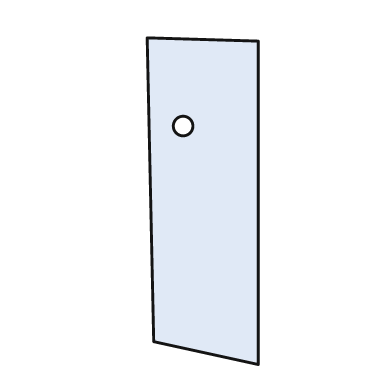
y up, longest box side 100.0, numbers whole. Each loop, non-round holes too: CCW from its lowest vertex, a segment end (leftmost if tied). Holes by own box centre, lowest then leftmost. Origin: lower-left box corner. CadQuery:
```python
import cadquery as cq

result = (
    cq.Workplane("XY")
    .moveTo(34.0, 0.0)
    .lineTo(34.0, 99.0)
    .lineTo(0.0, 100.0)
    .lineTo(2.0, 7.0)
    .close()
    .moveTo(11.0, 73.0)
    .circle(3.0)
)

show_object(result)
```